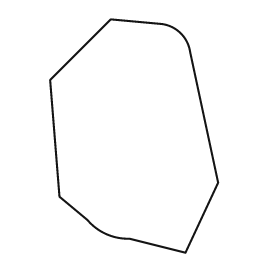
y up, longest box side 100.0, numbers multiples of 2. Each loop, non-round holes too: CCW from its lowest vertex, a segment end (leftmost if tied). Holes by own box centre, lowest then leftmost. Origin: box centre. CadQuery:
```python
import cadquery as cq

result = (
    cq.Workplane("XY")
    .moveTo(22.0, -50.0)
    .lineTo(36.0, -20.0)
    .lineTo(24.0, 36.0)
    .threePointArc((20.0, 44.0), (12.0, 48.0))
    .lineTo(-10.0, 50.0)
    .lineTo(-36.0, 24.0)
    .lineTo(-32.0, -26.0)
    .lineTo(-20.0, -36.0)
    .threePointArc((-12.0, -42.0), (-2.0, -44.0))
    .close()
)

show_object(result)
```